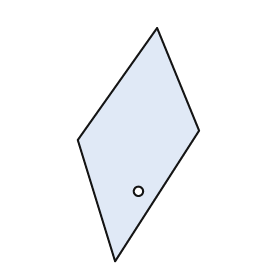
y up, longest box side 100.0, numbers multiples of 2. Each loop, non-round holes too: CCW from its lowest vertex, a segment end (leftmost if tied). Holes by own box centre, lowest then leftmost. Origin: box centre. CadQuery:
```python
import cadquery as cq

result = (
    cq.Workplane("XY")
    .moveTo(-10.0, -50.0)
    .lineTo(26.0, 6.0)
    .lineTo(8.0, 50.0)
    .lineTo(-26.0, 2.0)
    .close()
    .moveTo(0.0, -20.0)
    .circle(2.0)
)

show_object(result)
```